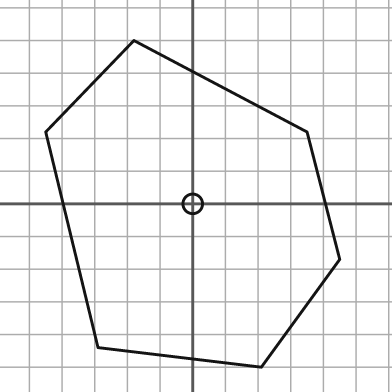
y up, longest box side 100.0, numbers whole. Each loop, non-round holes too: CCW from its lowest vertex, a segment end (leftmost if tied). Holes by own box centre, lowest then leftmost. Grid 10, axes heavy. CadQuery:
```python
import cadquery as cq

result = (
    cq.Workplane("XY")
    .moveTo(21.0, -50.0)
    .lineTo(45.0, -17.0)
    .lineTo(35.0, 22.0)
    .lineTo(-18.0, 50.0)
    .lineTo(-45.0, 22.0)
    .lineTo(-29.0, -44.0)
    .close()
    .moveTo(0.0, 0.0)
    .circle(3.0)
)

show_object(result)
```